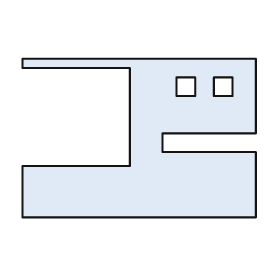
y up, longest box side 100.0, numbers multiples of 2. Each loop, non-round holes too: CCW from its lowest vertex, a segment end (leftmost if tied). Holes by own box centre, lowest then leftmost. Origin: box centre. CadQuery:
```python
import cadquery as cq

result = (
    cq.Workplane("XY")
    .moveTo(-50.0, -34.0)
    .lineTo(50.0, -34.0)
    .lineTo(50.0, -6.0)
    .lineTo(10.0, -6.0)
    .lineTo(10.0, 2.0)
    .lineTo(50.0, 2.0)
    .lineTo(50.0, 34.0)
    .lineTo(-50.0, 34.0)
    .lineTo(-50.0, 30.0)
    .lineTo(-4.0, 30.0)
    .lineTo(-4.0, -12.0)
    .lineTo(-50.0, -12.0)
    .close()
    .moveTo(16.0, 18.0)
    .lineTo(24.0, 18.0)
    .lineTo(24.0, 26.0)
    .lineTo(16.0, 26.0)
    .close()
    .moveTo(32.0, 18.0)
    .lineTo(40.0, 18.0)
    .lineTo(40.0, 26.0)
    .lineTo(32.0, 26.0)
    .close()
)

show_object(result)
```